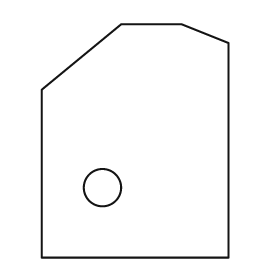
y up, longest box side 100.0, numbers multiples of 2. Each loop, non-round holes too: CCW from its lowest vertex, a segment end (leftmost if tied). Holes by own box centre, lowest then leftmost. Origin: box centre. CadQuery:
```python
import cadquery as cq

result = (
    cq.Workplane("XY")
    .moveTo(-40.0, -50.0)
    .lineTo(40.0, -50.0)
    .lineTo(40.0, 42.0)
    .lineTo(20.0, 50.0)
    .lineTo(-6.0, 50.0)
    .lineTo(-40.0, 22.0)
    .close()
    .moveTo(-14.0, -20.0)
    .circle(8.0)
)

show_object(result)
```